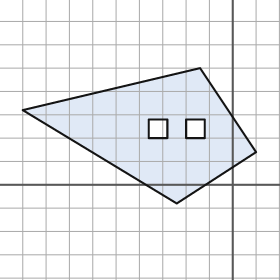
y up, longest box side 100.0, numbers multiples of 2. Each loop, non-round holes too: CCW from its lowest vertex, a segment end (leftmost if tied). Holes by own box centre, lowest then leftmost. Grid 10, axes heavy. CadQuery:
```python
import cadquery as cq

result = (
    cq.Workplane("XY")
    .moveTo(-24.0, -8.0)
    .lineTo(10.0, 14.0)
    .lineTo(-14.0, 50.0)
    .lineTo(-90.0, 32.0)
    .close()
    .moveTo(-36.0, 20.0)
    .lineTo(-28.0, 20.0)
    .lineTo(-28.0, 28.0)
    .lineTo(-36.0, 28.0)
    .close()
    .moveTo(-20.0, 20.0)
    .lineTo(-12.0, 20.0)
    .lineTo(-12.0, 28.0)
    .lineTo(-20.0, 28.0)
    .close()
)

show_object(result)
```